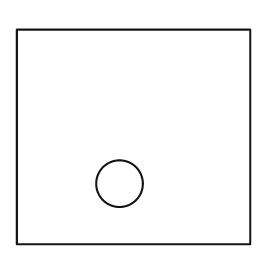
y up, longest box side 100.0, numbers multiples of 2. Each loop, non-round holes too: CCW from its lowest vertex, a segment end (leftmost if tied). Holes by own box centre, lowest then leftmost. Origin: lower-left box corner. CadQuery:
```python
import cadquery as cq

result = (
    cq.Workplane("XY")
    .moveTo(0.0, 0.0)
    .lineTo(100.0, 0.0)
    .lineTo(100.0, 92.0)
    .lineTo(0.0, 92.0)
    .close()
    .moveTo(44.0, 26.0)
    .circle(10.0)
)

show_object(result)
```